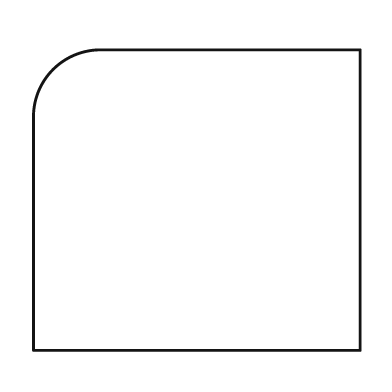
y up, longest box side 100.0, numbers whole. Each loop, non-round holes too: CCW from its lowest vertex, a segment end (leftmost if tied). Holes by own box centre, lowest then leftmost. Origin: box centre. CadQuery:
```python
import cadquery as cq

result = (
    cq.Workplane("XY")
    .moveTo(-50.0, -46.0)
    .lineTo(50.0, -46.0)
    .lineTo(50.0, 46.0)
    .lineTo(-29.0, 46.0)
    .threePointArc((-44.0, 40.0), (-50.0, 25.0))
    .close()
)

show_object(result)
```